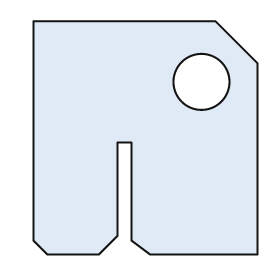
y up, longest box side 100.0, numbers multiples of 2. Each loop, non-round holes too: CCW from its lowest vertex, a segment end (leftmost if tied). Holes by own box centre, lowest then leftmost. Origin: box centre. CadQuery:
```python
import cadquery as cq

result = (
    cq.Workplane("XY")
    .moveTo(-42.0, -50.0)
    .lineTo(-20.0, -50.0)
    .lineTo(-12.0, -42.0)
    .lineTo(-12.0, -2.0)
    .lineTo(-6.0, -2.0)
    .lineTo(-6.0, -44.0)
    .lineTo(2.0, -50.0)
    .lineTo(48.0, -50.0)
    .lineTo(48.0, 32.0)
    .lineTo(30.0, 50.0)
    .lineTo(-48.0, 50.0)
    .lineTo(-48.0, -44.0)
    .close()
    .moveTo(24.0, 24.0)
    .circle(12.0)
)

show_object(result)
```